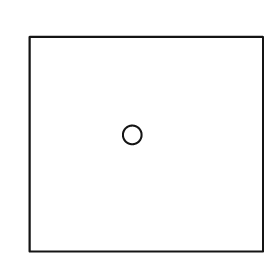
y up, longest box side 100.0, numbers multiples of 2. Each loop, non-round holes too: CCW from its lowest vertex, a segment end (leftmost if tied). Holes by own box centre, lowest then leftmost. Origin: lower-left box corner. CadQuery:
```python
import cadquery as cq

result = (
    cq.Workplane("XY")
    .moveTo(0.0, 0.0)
    .lineTo(100.0, 0.0)
    .lineTo(100.0, 92.0)
    .lineTo(0.0, 92.0)
    .close()
    .moveTo(44.0, 50.0)
    .circle(4.0)
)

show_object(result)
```